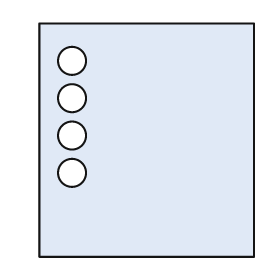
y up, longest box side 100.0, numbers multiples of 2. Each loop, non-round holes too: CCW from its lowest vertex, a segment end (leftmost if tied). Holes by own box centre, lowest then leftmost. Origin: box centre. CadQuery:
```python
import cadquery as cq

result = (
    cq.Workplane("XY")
    .moveTo(-46.0, -50.0)
    .lineTo(46.0, -50.0)
    .lineTo(46.0, 50.0)
    .lineTo(-46.0, 50.0)
    .close()
    .moveTo(-32.0, -14.0)
    .circle(6.0)
    .moveTo(-32.0, 2.0)
    .circle(6.0)
    .moveTo(-32.0, 18.0)
    .circle(6.0)
    .moveTo(-32.0, 34.0)
    .circle(6.0)
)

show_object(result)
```